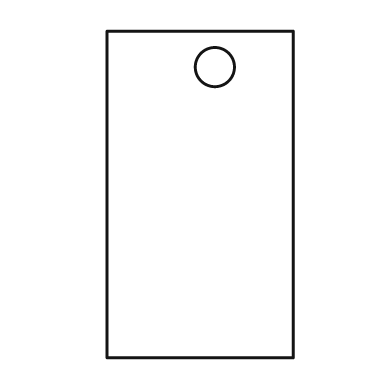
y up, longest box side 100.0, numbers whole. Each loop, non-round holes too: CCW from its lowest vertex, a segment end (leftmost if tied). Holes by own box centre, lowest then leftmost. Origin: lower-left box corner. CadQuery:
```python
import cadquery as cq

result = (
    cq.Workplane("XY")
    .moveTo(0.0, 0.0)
    .lineTo(57.0, 0.0)
    .lineTo(57.0, 100.0)
    .lineTo(0.0, 100.0)
    .close()
    .moveTo(33.0, 89.0)
    .circle(6.0)
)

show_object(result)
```